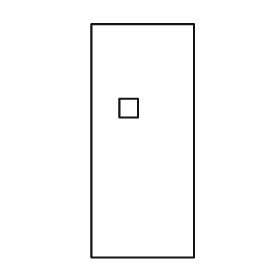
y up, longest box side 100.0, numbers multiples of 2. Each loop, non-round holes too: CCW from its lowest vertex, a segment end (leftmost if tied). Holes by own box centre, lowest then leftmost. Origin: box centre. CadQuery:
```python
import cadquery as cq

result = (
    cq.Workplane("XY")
    .moveTo(-22.0, -50.0)
    .lineTo(22.0, -50.0)
    .lineTo(22.0, 50.0)
    .lineTo(-22.0, 50.0)
    .close()
    .moveTo(-10.0, 10.0)
    .lineTo(-2.0, 10.0)
    .lineTo(-2.0, 18.0)
    .lineTo(-10.0, 18.0)
    .close()
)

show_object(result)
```